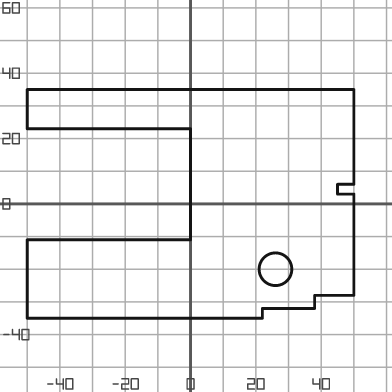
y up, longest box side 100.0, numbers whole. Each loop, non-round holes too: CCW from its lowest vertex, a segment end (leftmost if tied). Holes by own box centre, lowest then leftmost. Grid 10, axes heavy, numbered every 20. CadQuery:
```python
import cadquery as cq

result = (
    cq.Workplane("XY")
    .moveTo(-50.0, -35.0)
    .lineTo(22.0, -35.0)
    .lineTo(22.0, -32.0)
    .lineTo(38.0, -32.0)
    .lineTo(38.0, -28.0)
    .lineTo(50.0, -28.0)
    .lineTo(50.0, 3.0)
    .lineTo(45.0, 3.0)
    .lineTo(45.0, 6.0)
    .lineTo(50.0, 6.0)
    .lineTo(50.0, 35.0)
    .lineTo(-50.0, 35.0)
    .lineTo(-50.0, 23.0)
    .lineTo(0.0, 23.0)
    .lineTo(0.0, -11.0)
    .lineTo(-50.0, -11.0)
    .close()
    .moveTo(26.0, -20.0)
    .circle(5.0)
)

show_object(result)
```